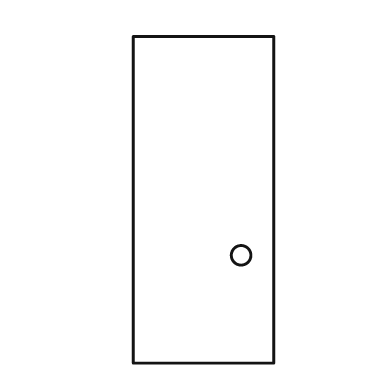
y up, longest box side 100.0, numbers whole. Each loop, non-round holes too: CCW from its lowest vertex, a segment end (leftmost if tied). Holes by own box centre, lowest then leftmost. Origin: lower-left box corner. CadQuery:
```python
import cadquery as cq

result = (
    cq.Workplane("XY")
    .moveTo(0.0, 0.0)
    .lineTo(43.0, 0.0)
    .lineTo(43.0, 100.0)
    .lineTo(0.0, 100.0)
    .close()
    .moveTo(33.0, 33.0)
    .circle(3.0)
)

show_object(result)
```